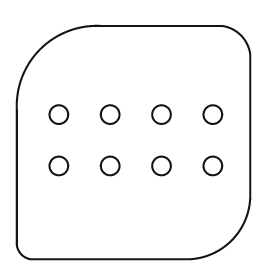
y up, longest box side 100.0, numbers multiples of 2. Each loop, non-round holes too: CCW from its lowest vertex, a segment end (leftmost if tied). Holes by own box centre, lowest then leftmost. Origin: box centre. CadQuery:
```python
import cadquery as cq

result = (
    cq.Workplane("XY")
    .moveTo(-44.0, -50.0)
    .lineTo(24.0, -50.0)
    .threePointArc((42.0, -42.0), (50.0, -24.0))
    .lineTo(50.0, 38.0)
    .threePointArc((46.0, 46.0), (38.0, 50.0))
    .lineTo(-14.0, 50.0)
    .threePointArc((-40.0, 40.0), (-50.0, 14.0))
    .lineTo(-50.0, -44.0)
    .threePointArc((-48.0, -48.0), (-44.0, -50.0))
    .close()
    .moveTo(-32.0, -10.0)
    .circle(4.0)
    .moveTo(-10.0, -10.0)
    .circle(4.0)
    .moveTo(12.0, -10.0)
    .circle(4.0)
    .moveTo(34.0, -10.0)
    .circle(4.0)
    .moveTo(-32.0, 12.0)
    .circle(4.0)
    .moveTo(-10.0, 12.0)
    .circle(4.0)
    .moveTo(12.0, 12.0)
    .circle(4.0)
    .moveTo(34.0, 12.0)
    .circle(4.0)
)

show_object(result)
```